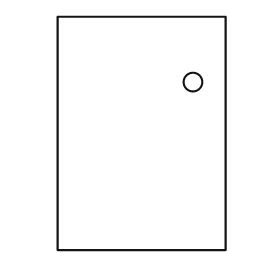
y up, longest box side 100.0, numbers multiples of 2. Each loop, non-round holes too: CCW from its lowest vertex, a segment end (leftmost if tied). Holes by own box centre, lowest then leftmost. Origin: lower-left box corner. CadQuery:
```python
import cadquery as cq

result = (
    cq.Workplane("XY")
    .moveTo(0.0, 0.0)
    .lineTo(72.0, 0.0)
    .lineTo(72.0, 100.0)
    .lineTo(0.0, 100.0)
    .close()
    .moveTo(58.0, 72.0)
    .circle(4.0)
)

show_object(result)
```